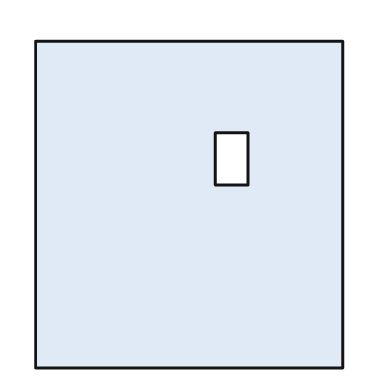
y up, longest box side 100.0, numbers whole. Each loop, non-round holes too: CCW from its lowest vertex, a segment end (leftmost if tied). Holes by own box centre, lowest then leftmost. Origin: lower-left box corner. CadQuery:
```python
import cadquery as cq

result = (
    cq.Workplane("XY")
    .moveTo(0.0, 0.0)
    .lineTo(94.0, 0.0)
    .lineTo(94.0, 100.0)
    .lineTo(0.0, 100.0)
    .close()
    .moveTo(55.0, 56.0)
    .lineTo(65.0, 56.0)
    .lineTo(65.0, 72.0)
    .lineTo(55.0, 72.0)
    .close()
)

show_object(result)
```